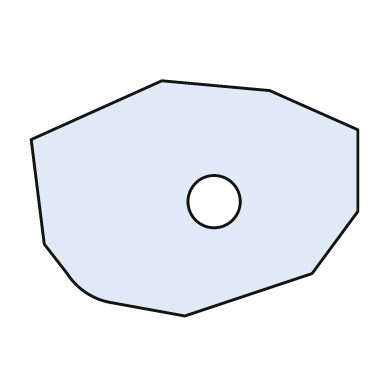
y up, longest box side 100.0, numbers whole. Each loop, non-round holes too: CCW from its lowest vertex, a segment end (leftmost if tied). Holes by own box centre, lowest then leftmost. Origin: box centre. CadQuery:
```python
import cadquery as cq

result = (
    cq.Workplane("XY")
    .moveTo(-3.0, -36.0)
    .lineTo(36.0, -23.0)
    .lineTo(50.0, -4.0)
    .lineTo(50.0, 21.0)
    .lineTo(23.0, 33.0)
    .lineTo(-10.0, 36.0)
    .lineTo(-50.0, 18.0)
    .lineTo(-46.0, -14.0)
    .lineTo(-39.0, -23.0)
    .threePointArc((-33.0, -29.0), (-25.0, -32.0))
    .close()
    .moveTo(6.0, -1.0)
    .circle(8.0)
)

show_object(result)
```